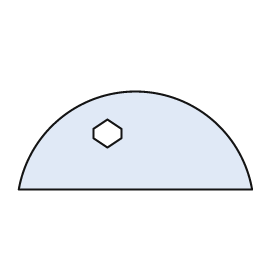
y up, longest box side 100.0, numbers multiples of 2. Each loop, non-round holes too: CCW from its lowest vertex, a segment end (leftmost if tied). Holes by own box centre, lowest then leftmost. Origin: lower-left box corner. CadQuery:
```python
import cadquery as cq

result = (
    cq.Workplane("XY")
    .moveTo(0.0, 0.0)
    .lineTo(100.0, 0.0)
    .threePointArc((50.0, 42.0), (0.0, 0.0))
    .close()
    .moveTo(38.0, 18.0)
    .lineTo(44.0, 22.0)
    .lineTo(44.0, 26.0)
    .lineTo(38.0, 30.0)
    .lineTo(32.0, 26.0)
    .lineTo(32.0, 22.0)
    .close()
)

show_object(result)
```